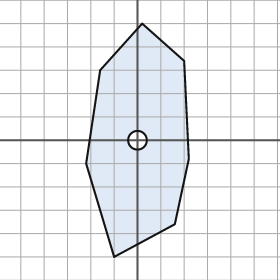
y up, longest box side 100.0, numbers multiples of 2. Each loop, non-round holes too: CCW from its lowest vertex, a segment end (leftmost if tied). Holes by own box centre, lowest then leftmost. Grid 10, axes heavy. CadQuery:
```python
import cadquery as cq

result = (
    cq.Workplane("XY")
    .moveTo(-10.0, -50.0)
    .lineTo(16.0, -36.0)
    .lineTo(22.0, -8.0)
    .lineTo(20.0, 34.0)
    .lineTo(2.0, 50.0)
    .lineTo(-16.0, 30.0)
    .lineTo(-22.0, -10.0)
    .close()
    .moveTo(0.0, 0.0)
    .circle(4.0)
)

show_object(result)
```